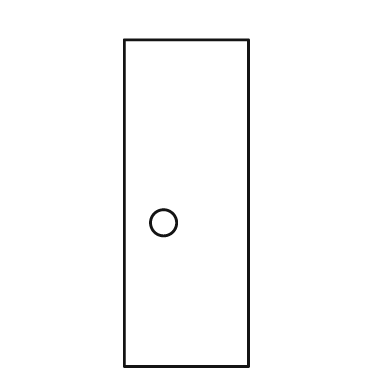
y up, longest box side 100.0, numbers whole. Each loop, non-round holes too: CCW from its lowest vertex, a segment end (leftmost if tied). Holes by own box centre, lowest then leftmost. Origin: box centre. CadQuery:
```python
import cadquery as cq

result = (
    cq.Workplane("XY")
    .moveTo(-19.0, -50.0)
    .lineTo(19.0, -50.0)
    .lineTo(19.0, 50.0)
    .lineTo(-19.0, 50.0)
    .close()
    .moveTo(-7.0, -6.0)
    .circle(4.0)
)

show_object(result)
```